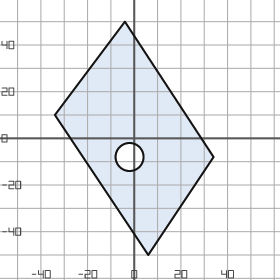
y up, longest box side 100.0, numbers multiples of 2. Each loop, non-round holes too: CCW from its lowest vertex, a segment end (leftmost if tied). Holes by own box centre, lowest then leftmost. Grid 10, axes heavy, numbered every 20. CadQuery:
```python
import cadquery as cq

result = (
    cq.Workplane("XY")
    .moveTo(6.0, -50.0)
    .lineTo(34.0, -8.0)
    .lineTo(-4.0, 50.0)
    .lineTo(-34.0, 10.0)
    .close()
    .moveTo(-2.0, -8.0)
    .circle(6.0)
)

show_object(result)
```